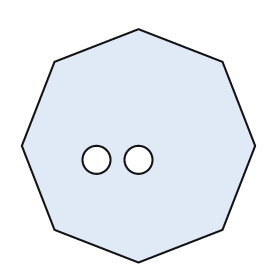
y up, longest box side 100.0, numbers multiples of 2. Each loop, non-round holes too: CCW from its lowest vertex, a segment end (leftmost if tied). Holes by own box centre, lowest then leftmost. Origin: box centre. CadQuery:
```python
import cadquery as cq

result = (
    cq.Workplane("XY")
    .moveTo(0.0, -50.0)
    .lineTo(36.0, -36.0)
    .lineTo(50.0, 0.0)
    .lineTo(36.0, 36.0)
    .lineTo(0.0, 50.0)
    .lineTo(-36.0, 36.0)
    .lineTo(-50.0, 0.0)
    .lineTo(-36.0, -36.0)
    .close()
    .moveTo(-18.0, -6.0)
    .circle(6.0)
    .moveTo(0.0, -6.0)
    .circle(6.0)
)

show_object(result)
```